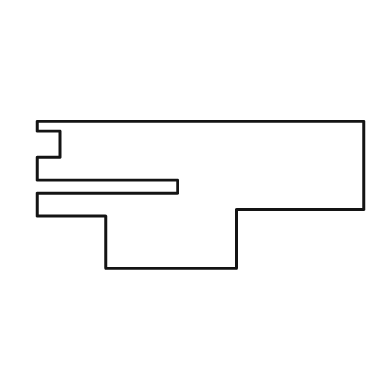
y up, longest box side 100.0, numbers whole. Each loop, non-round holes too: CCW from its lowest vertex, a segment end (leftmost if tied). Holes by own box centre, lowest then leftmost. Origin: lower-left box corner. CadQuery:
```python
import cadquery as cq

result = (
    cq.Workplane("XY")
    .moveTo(21.0, 0.0)
    .lineTo(61.0, 0.0)
    .lineTo(61.0, 18.0)
    .lineTo(100.0, 18.0)
    .lineTo(100.0, 45.0)
    .lineTo(0.0, 45.0)
    .lineTo(0.0, 42.0)
    .lineTo(7.0, 42.0)
    .lineTo(7.0, 34.0)
    .lineTo(0.0, 34.0)
    .lineTo(0.0, 27.0)
    .lineTo(43.0, 27.0)
    .lineTo(43.0, 23.0)
    .lineTo(0.0, 23.0)
    .lineTo(0.0, 16.0)
    .lineTo(21.0, 16.0)
    .close()
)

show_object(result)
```